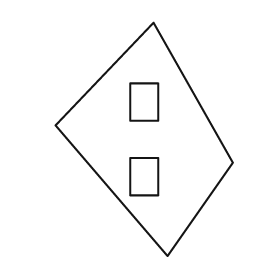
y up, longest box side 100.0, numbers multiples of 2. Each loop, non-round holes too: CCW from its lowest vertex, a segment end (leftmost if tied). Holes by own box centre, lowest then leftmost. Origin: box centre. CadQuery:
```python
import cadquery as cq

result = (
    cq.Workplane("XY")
    .moveTo(10.0, -50.0)
    .lineTo(38.0, -10.0)
    .lineTo(4.0, 50.0)
    .lineTo(-38.0, 6.0)
    .close()
    .moveTo(-6.0, -24.0)
    .lineTo(6.0, -24.0)
    .lineTo(6.0, -8.0)
    .lineTo(-6.0, -8.0)
    .close()
    .moveTo(-6.0, 8.0)
    .lineTo(6.0, 8.0)
    .lineTo(6.0, 24.0)
    .lineTo(-6.0, 24.0)
    .close()
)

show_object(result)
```